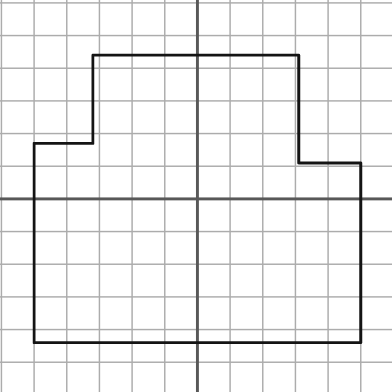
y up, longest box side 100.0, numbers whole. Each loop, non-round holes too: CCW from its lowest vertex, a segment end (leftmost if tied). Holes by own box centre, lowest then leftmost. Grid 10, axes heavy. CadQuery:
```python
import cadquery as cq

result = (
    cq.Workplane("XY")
    .moveTo(-50.0, -44.0)
    .lineTo(50.0, -44.0)
    .lineTo(50.0, 11.0)
    .lineTo(31.0, 11.0)
    .lineTo(31.0, 44.0)
    .lineTo(-32.0, 44.0)
    .lineTo(-32.0, 17.0)
    .lineTo(-50.0, 17.0)
    .close()
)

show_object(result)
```